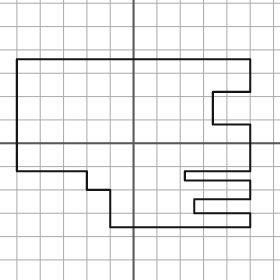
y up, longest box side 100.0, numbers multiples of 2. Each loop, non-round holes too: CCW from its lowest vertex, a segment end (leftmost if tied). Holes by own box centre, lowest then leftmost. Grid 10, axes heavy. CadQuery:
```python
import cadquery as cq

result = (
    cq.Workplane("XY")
    .moveTo(-10.0, -36.0)
    .lineTo(50.0, -36.0)
    .lineTo(50.0, -30.0)
    .lineTo(26.0, -30.0)
    .lineTo(26.0, -24.0)
    .lineTo(50.0, -24.0)
    .lineTo(50.0, -16.0)
    .lineTo(22.0, -16.0)
    .lineTo(22.0, -12.0)
    .lineTo(50.0, -12.0)
    .lineTo(50.0, 8.0)
    .lineTo(34.0, 8.0)
    .lineTo(34.0, 22.0)
    .lineTo(50.0, 22.0)
    .lineTo(50.0, 36.0)
    .lineTo(-50.0, 36.0)
    .lineTo(-50.0, -12.0)
    .lineTo(-20.0, -12.0)
    .lineTo(-20.0, -20.0)
    .lineTo(-10.0, -20.0)
    .close()
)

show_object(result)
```